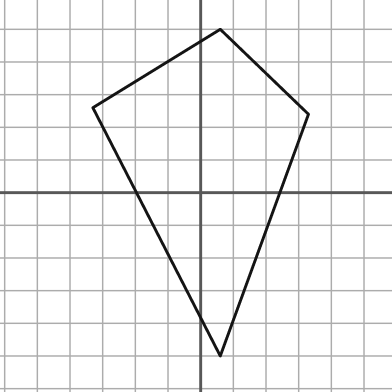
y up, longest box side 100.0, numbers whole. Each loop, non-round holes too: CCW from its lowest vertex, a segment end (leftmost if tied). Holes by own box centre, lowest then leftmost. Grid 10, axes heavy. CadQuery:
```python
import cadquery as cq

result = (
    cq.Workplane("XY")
    .moveTo(6.0, -50.0)
    .lineTo(33.0, 24.0)
    .lineTo(6.0, 50.0)
    .lineTo(-33.0, 26.0)
    .close()
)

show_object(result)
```